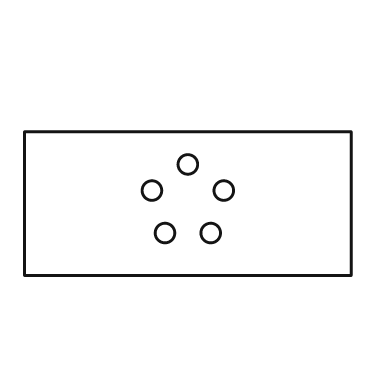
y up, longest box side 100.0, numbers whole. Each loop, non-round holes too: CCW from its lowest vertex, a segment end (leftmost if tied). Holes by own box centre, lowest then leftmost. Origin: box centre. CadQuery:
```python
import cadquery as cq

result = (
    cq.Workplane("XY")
    .moveTo(-50.0, -22.0)
    .lineTo(50.0, -22.0)
    .lineTo(50.0, 22.0)
    .lineTo(-50.0, 22.0)
    .close()
    .moveTo(-7.0, -9.0)
    .circle(3.0)
    .moveTo(7.0, -9.0)
    .circle(3.0)
    .moveTo(-11.0, 4.0)
    .circle(3.0)
    .moveTo(11.0, 4.0)
    .circle(3.0)
    .moveTo(0.0, 12.0)
    .circle(3.0)
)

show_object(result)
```